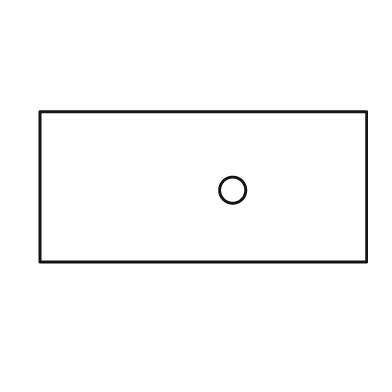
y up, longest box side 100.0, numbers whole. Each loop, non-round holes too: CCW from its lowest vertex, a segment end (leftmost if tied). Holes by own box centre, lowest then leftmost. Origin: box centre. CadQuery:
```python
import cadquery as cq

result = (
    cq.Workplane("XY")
    .moveTo(-50.0, -23.0)
    .lineTo(50.0, -23.0)
    .lineTo(50.0, 23.0)
    .lineTo(-50.0, 23.0)
    .close()
    .moveTo(9.0, -1.0)
    .circle(4.0)
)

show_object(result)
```